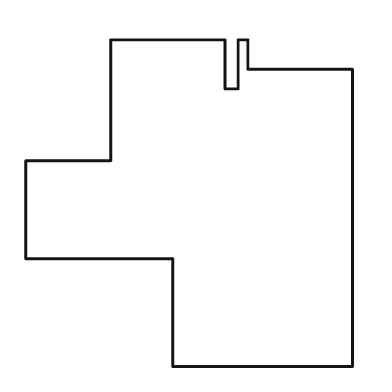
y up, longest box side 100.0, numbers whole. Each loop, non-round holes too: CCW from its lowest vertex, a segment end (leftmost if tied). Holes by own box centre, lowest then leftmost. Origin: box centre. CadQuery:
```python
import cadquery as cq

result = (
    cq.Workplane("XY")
    .moveTo(-5.0, -50.0)
    .lineTo(50.0, -50.0)
    .lineTo(50.0, 41.0)
    .lineTo(18.0, 41.0)
    .lineTo(18.0, 50.0)
    .lineTo(15.0, 50.0)
    .lineTo(15.0, 35.0)
    .lineTo(11.0, 35.0)
    .lineTo(11.0, 50.0)
    .lineTo(-24.0, 50.0)
    .lineTo(-24.0, 13.0)
    .lineTo(-50.0, 13.0)
    .lineTo(-50.0, -17.0)
    .lineTo(-5.0, -17.0)
    .close()
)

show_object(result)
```